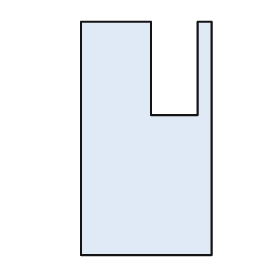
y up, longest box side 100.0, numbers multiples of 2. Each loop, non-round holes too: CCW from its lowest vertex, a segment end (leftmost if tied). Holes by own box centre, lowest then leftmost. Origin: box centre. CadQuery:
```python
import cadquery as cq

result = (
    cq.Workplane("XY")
    .moveTo(-28.0, -50.0)
    .lineTo(28.0, -50.0)
    .lineTo(28.0, 50.0)
    .lineTo(22.0, 50.0)
    .lineTo(22.0, 10.0)
    .lineTo(2.0, 10.0)
    .lineTo(2.0, 50.0)
    .lineTo(-28.0, 50.0)
    .close()
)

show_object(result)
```